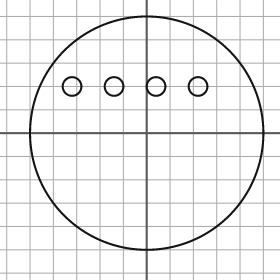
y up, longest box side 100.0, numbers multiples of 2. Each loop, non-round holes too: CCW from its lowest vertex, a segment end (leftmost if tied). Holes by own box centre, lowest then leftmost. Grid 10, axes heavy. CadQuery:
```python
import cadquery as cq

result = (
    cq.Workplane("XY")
    .moveTo(0.0, 0.0)
    .circle(50.0)
    .moveTo(-32.0, 20.0)
    .circle(4.0)
    .moveTo(-14.0, 20.0)
    .circle(4.0)
    .moveTo(4.0, 20.0)
    .circle(4.0)
    .moveTo(22.0, 20.0)
    .circle(4.0)
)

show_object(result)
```